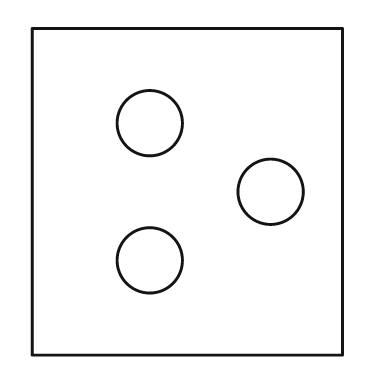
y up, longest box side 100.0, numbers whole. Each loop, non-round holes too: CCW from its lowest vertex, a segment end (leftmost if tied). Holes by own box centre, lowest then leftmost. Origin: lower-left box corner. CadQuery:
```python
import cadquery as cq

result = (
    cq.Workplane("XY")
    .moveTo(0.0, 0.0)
    .lineTo(95.0, 0.0)
    .lineTo(95.0, 100.0)
    .lineTo(0.0, 100.0)
    .close()
    .moveTo(36.0, 29.0)
    .circle(10.0)
    .moveTo(73.0, 50.0)
    .circle(10.0)
    .moveTo(36.0, 71.0)
    .circle(10.0)
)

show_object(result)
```